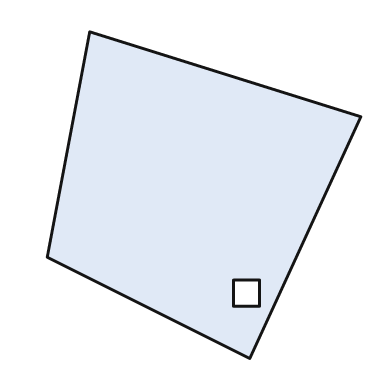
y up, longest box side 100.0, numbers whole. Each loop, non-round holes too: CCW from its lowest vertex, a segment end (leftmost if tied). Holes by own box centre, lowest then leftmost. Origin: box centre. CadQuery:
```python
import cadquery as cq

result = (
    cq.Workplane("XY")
    .moveTo(14.0, -50.0)
    .lineTo(48.0, 24.0)
    .lineTo(-35.0, 50.0)
    .lineTo(-48.0, -19.0)
    .close()
    .moveTo(9.0, -34.0)
    .lineTo(17.0, -34.0)
    .lineTo(17.0, -26.0)
    .lineTo(9.0, -26.0)
    .close()
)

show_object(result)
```